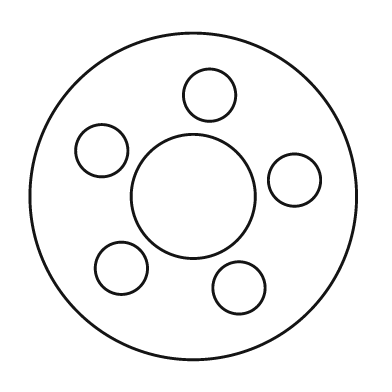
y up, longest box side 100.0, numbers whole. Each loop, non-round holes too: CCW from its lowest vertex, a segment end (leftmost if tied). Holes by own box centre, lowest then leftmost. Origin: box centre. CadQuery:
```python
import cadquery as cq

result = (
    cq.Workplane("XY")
    .moveTo(0.0, 0.0)
    .circle(50.0)
    .moveTo(14.0, -28.0)
    .circle(8.0)
    .moveTo(-22.0, -22.0)
    .circle(8.0)
    .moveTo(0.0, 0.0)
    .circle(19.0)
    .moveTo(31.0, 5.0)
    .circle(8.0)
    .moveTo(-28.0, 14.0)
    .circle(8.0)
    .moveTo(5.0, 31.0)
    .circle(8.0)
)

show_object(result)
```